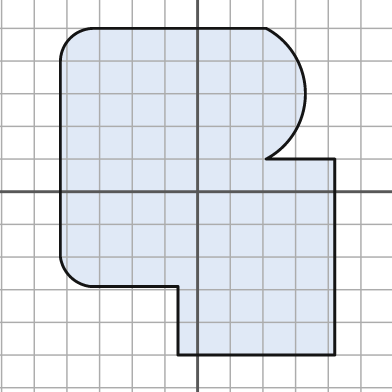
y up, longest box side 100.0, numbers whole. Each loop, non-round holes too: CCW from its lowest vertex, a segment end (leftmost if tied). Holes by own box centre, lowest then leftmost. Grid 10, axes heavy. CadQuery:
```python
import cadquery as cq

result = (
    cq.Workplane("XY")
    .moveTo(-6.0, -50.0)
    .lineTo(42.0, -50.0)
    .lineTo(42.0, 10.0)
    .lineTo(21.0, 10.0)
    .threePointArc((33.0, 30.0), (21.0, 50.0))
    .lineTo(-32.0, 50.0)
    .threePointArc((-39.0, 47.0), (-42.0, 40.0))
    .lineTo(-42.0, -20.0)
    .threePointArc((-39.0, -26.0), (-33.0, -29.0))
    .lineTo(-6.0, -29.0)
    .close()
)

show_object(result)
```